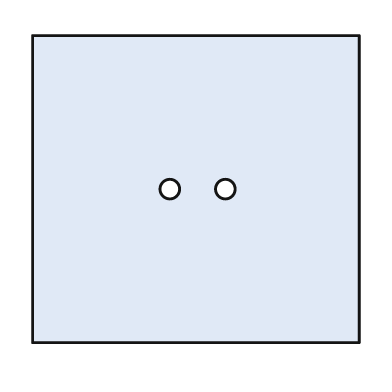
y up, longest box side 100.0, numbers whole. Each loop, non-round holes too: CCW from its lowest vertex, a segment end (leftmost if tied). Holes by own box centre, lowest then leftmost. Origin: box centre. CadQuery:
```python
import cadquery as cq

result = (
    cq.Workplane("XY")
    .moveTo(-50.0, -47.0)
    .lineTo(50.0, -47.0)
    .lineTo(50.0, 47.0)
    .lineTo(-50.0, 47.0)
    .close()
    .moveTo(-8.0, 0.0)
    .circle(3.0)
    .moveTo(9.0, 0.0)
    .circle(3.0)
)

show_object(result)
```